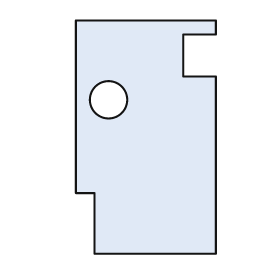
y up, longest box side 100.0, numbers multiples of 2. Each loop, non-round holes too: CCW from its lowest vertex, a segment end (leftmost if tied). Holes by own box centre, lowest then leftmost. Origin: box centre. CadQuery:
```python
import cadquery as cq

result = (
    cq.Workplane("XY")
    .moveTo(-22.0, -50.0)
    .lineTo(30.0, -50.0)
    .lineTo(30.0, 26.0)
    .lineTo(16.0, 26.0)
    .lineTo(16.0, 44.0)
    .lineTo(30.0, 44.0)
    .lineTo(30.0, 50.0)
    .lineTo(-30.0, 50.0)
    .lineTo(-30.0, -24.0)
    .lineTo(-22.0, -24.0)
    .close()
    .moveTo(-16.0, 16.0)
    .circle(8.0)
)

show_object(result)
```